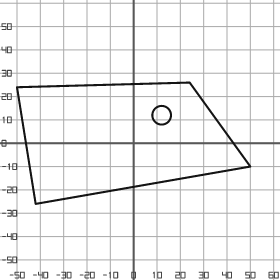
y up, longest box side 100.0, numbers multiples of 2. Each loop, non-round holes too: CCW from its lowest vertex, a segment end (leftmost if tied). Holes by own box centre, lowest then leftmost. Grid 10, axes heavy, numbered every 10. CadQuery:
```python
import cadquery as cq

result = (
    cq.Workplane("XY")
    .moveTo(-42.0, -26.0)
    .lineTo(50.0, -10.0)
    .lineTo(24.0, 26.0)
    .lineTo(-50.0, 24.0)
    .close()
    .moveTo(12.0, 12.0)
    .circle(4.0)
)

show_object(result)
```